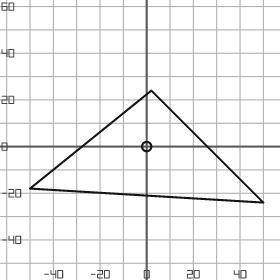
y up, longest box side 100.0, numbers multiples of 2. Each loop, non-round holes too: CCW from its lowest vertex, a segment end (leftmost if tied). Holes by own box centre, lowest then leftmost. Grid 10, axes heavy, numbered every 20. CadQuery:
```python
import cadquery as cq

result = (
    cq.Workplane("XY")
    .moveTo(50.0, -24.0)
    .lineTo(2.0, 24.0)
    .lineTo(-50.0, -18.0)
    .close()
    .moveTo(0.0, 0.0)
    .circle(2.0)
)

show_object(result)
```